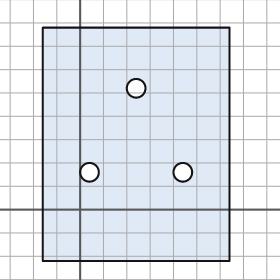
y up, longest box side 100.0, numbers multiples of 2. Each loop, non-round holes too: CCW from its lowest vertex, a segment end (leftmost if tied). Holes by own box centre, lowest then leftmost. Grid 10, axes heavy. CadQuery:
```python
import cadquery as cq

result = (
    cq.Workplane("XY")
    .moveTo(-16.0, -22.0)
    .lineTo(64.0, -22.0)
    .lineTo(64.0, 78.0)
    .lineTo(-16.0, 78.0)
    .close()
    .moveTo(4.0, 16.0)
    .circle(4.0)
    .moveTo(44.0, 16.0)
    .circle(4.0)
    .moveTo(24.0, 52.0)
    .circle(4.0)
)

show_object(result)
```